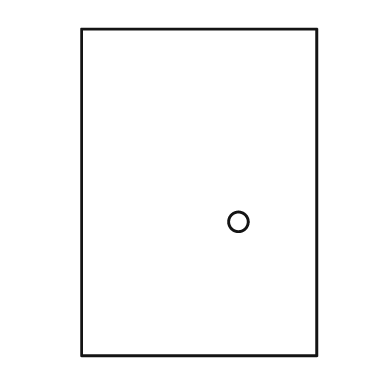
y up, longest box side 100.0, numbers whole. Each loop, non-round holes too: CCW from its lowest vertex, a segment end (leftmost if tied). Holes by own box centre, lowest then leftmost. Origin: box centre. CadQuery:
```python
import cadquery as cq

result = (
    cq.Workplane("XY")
    .moveTo(-36.0, -50.0)
    .lineTo(36.0, -50.0)
    .lineTo(36.0, 50.0)
    .lineTo(-36.0, 50.0)
    .close()
    .moveTo(12.0, -9.0)
    .circle(3.0)
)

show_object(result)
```